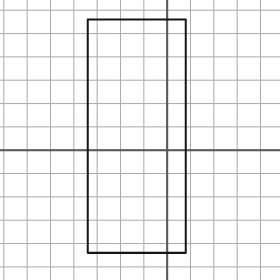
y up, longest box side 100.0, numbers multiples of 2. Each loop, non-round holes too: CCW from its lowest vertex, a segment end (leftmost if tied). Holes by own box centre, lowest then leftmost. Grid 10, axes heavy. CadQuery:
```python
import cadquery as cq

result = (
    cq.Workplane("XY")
    .moveTo(-34.0, -44.0)
    .lineTo(8.0, -44.0)
    .lineTo(8.0, 56.0)
    .lineTo(-34.0, 56.0)
    .close()
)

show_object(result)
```